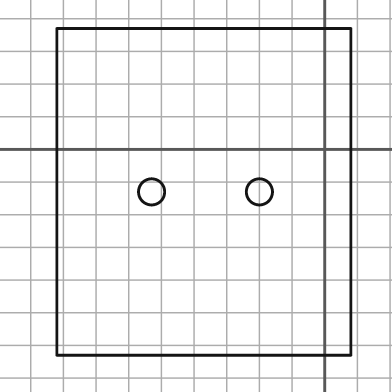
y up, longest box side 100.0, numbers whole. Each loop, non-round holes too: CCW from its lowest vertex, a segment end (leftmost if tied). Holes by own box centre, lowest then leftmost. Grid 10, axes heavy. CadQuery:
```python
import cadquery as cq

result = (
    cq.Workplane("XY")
    .moveTo(-82.0, -63.0)
    .lineTo(8.0, -63.0)
    .lineTo(8.0, 37.0)
    .lineTo(-82.0, 37.0)
    .close()
    .moveTo(-53.0, -13.0)
    .circle(4.0)
    .moveTo(-20.0, -13.0)
    .circle(4.0)
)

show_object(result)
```